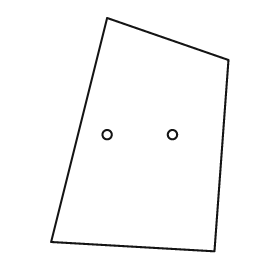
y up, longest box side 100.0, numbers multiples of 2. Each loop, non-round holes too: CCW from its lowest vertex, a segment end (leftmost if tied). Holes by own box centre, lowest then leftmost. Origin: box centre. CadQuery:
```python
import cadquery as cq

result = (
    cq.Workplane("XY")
    .moveTo(32.0, -50.0)
    .lineTo(38.0, 32.0)
    .lineTo(-14.0, 50.0)
    .lineTo(-38.0, -46.0)
    .close()
    .moveTo(-14.0, 0.0)
    .circle(2.0)
    .moveTo(14.0, 0.0)
    .circle(2.0)
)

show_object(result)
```